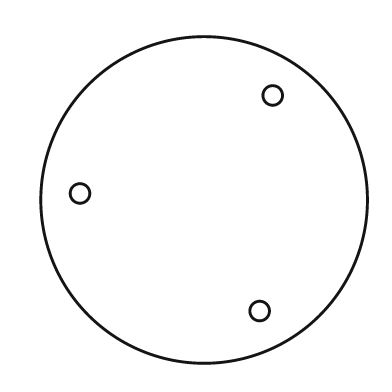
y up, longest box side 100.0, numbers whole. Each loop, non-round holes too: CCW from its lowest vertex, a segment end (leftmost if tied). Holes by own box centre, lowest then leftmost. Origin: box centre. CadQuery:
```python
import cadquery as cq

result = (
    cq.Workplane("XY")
    .moveTo(0.0, 0.0)
    .circle(50.0)
    .moveTo(17.0, -34.0)
    .circle(3.0)
    .moveTo(-38.0, 2.0)
    .circle(3.0)
    .moveTo(21.0, 32.0)
    .circle(3.0)
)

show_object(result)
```